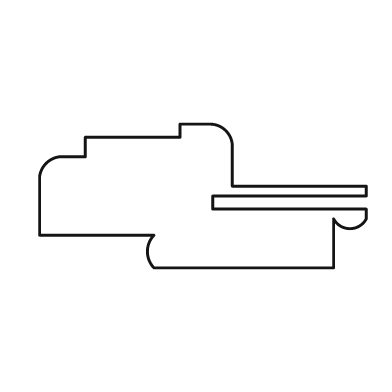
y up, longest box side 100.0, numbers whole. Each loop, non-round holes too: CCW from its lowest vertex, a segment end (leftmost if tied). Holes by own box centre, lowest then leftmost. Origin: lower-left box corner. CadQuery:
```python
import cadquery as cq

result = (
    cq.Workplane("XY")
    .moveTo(35.0, 0.0)
    .lineTo(90.0, 0.0)
    .lineTo(90.0, 15.0)
    .threePointArc((95.0, 12.0), (100.0, 15.0))
    .lineTo(100.0, 18.0)
    .lineTo(53.0, 18.0)
    .lineTo(53.0, 22.0)
    .lineTo(100.0, 22.0)
    .lineTo(100.0, 25.0)
    .lineTo(59.0, 25.0)
    .lineTo(59.0, 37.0)
    .threePointArc((57.0, 42.0), (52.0, 44.0))
    .lineTo(43.0, 44.0)
    .lineTo(43.0, 40.0)
    .lineTo(14.0, 40.0)
    .lineTo(14.0, 34.0)
    .lineTo(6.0, 34.0)
    .threePointArc((2.0, 32.0), (0.0, 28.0))
    .lineTo(0.0, 10.0)
    .lineTo(35.0, 10.0)
    .threePointArc((33.0, 5.0), (35.0, 0.0))
    .close()
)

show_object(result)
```